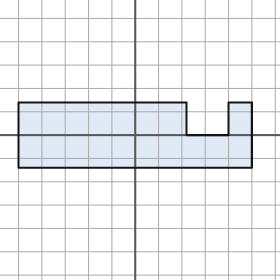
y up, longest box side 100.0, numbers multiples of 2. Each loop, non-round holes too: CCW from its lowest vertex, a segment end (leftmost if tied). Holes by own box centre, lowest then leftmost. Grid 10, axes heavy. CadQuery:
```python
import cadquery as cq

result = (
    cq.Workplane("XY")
    .moveTo(-50.0, -14.0)
    .lineTo(50.0, -14.0)
    .lineTo(50.0, 14.0)
    .lineTo(40.0, 14.0)
    .lineTo(40.0, 0.0)
    .lineTo(22.0, 0.0)
    .lineTo(22.0, 14.0)
    .lineTo(-50.0, 14.0)
    .close()
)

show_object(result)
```